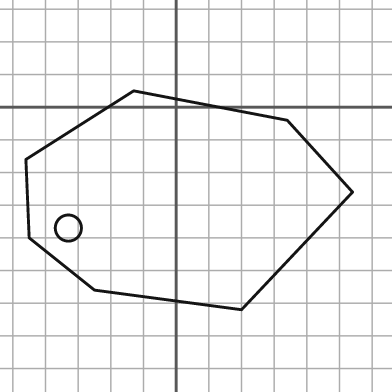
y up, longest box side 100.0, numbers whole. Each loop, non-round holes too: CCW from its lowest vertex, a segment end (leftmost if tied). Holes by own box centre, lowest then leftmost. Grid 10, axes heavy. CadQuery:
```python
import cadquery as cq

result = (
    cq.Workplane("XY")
    .moveTo(20.0, -62.0)
    .lineTo(54.0, -26.0)
    .lineTo(34.0, -4.0)
    .lineTo(-13.0, 5.0)
    .lineTo(-46.0, -16.0)
    .lineTo(-45.0, -40.0)
    .lineTo(-25.0, -56.0)
    .close()
    .moveTo(-33.0, -37.0)
    .circle(4.0)
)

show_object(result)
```